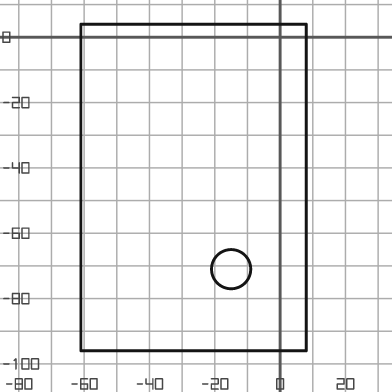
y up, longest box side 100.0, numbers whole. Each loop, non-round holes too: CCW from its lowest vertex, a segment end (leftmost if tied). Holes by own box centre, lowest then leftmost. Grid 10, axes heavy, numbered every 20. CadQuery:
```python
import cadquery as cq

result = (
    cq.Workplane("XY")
    .moveTo(-61.0, -96.0)
    .lineTo(8.0, -96.0)
    .lineTo(8.0, 4.0)
    .lineTo(-61.0, 4.0)
    .close()
    .moveTo(-15.0, -71.0)
    .circle(6.0)
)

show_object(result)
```